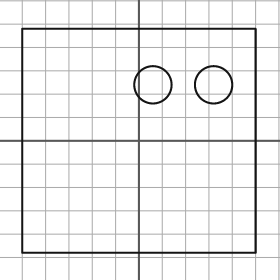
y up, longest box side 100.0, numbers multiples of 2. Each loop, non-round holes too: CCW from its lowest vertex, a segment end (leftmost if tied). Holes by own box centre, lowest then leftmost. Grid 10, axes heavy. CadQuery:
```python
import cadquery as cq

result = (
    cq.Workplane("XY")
    .moveTo(-50.0, -48.0)
    .lineTo(50.0, -48.0)
    .lineTo(50.0, 48.0)
    .lineTo(-50.0, 48.0)
    .close()
    .moveTo(6.0, 24.0)
    .circle(8.0)
    .moveTo(32.0, 24.0)
    .circle(8.0)
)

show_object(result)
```